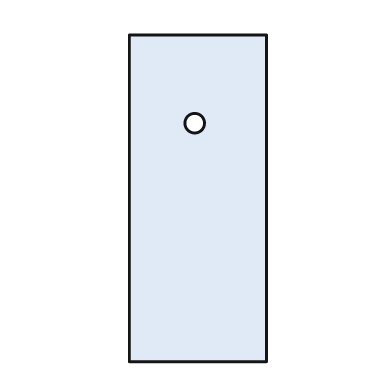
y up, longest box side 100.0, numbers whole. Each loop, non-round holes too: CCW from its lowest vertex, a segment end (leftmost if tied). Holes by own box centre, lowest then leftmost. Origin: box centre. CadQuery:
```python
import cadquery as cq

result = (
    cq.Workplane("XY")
    .moveTo(-21.0, -50.0)
    .lineTo(21.0, -50.0)
    .lineTo(21.0, 50.0)
    .lineTo(-21.0, 50.0)
    .close()
    .moveTo(-1.0, 23.0)
    .circle(3.0)
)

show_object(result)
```